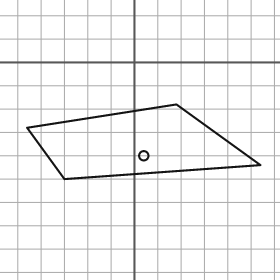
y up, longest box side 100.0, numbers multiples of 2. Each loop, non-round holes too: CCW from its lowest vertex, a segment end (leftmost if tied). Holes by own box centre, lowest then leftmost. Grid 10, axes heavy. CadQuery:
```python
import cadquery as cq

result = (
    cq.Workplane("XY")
    .moveTo(-30.0, -50.0)
    .lineTo(54.0, -44.0)
    .lineTo(18.0, -18.0)
    .lineTo(-46.0, -28.0)
    .close()
    .moveTo(4.0, -40.0)
    .circle(2.0)
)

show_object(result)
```